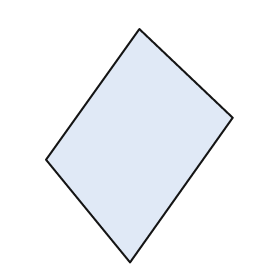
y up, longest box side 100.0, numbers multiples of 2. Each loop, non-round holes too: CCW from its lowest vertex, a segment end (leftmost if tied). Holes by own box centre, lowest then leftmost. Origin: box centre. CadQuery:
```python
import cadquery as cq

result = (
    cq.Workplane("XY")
    .moveTo(-4.0, -50.0)
    .lineTo(40.0, 12.0)
    .lineTo(0.0, 50.0)
    .lineTo(-40.0, -6.0)
    .close()
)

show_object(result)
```